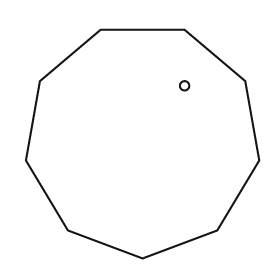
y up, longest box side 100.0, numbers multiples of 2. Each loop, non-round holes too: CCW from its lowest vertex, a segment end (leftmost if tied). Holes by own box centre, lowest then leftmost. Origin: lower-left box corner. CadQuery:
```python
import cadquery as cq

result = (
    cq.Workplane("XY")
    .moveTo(50.0, 0.0)
    .lineTo(82.0, 12.0)
    .lineTo(100.0, 42.0)
    .lineTo(94.0, 76.0)
    .lineTo(68.0, 98.0)
    .lineTo(32.0, 98.0)
    .lineTo(6.0, 76.0)
    .lineTo(0.0, 42.0)
    .lineTo(18.0, 12.0)
    .close()
    .moveTo(68.0, 74.0)
    .circle(2.0)
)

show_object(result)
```